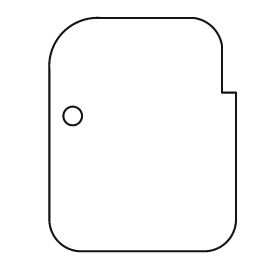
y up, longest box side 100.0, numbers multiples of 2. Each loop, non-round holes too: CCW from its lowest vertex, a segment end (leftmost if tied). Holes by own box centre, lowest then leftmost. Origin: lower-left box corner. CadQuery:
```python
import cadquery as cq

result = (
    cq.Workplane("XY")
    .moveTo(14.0, 0.0)
    .lineTo(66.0, 0.0)
    .threePointArc((76.0, 4.0), (80.0, 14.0))
    .lineTo(80.0, 68.0)
    .lineTo(74.0, 68.0)
    .lineTo(74.0, 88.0)
    .threePointArc((70.0, 96.0), (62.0, 100.0))
    .lineTo(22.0, 100.0)
    .threePointArc((6.0, 94.0), (0.0, 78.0))
    .lineTo(0.0, 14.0)
    .threePointArc((4.0, 4.0), (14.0, 0.0))
    .close()
    .moveTo(10.0, 58.0)
    .circle(4.0)
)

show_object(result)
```